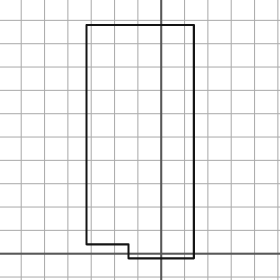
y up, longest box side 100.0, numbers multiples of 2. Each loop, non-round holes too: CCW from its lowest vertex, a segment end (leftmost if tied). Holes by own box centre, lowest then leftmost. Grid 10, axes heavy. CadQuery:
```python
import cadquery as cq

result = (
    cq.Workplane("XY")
    .moveTo(-14.0, -2.0)
    .lineTo(14.0, -2.0)
    .lineTo(14.0, 98.0)
    .lineTo(-32.0, 98.0)
    .lineTo(-32.0, 4.0)
    .lineTo(-14.0, 4.0)
    .close()
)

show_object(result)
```